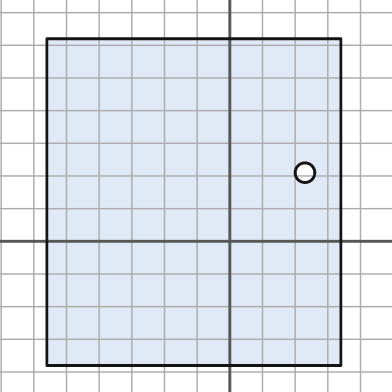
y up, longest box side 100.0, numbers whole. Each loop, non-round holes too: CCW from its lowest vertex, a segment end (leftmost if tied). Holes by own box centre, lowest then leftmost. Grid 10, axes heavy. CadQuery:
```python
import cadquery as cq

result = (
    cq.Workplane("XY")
    .moveTo(-56.0, -38.0)
    .lineTo(34.0, -38.0)
    .lineTo(34.0, 62.0)
    .lineTo(-56.0, 62.0)
    .close()
    .moveTo(23.0, 21.0)
    .circle(3.0)
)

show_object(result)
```